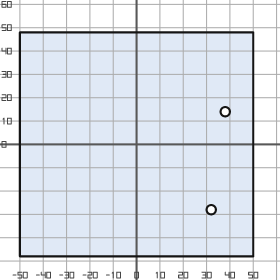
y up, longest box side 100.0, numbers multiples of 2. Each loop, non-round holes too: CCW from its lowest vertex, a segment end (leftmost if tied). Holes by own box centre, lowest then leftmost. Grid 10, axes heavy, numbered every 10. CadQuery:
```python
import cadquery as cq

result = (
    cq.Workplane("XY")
    .moveTo(-50.0, -48.0)
    .lineTo(50.0, -48.0)
    .lineTo(50.0, 48.0)
    .lineTo(-50.0, 48.0)
    .close()
    .moveTo(32.0, -28.0)
    .circle(2.0)
    .moveTo(38.0, 14.0)
    .circle(2.0)
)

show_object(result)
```